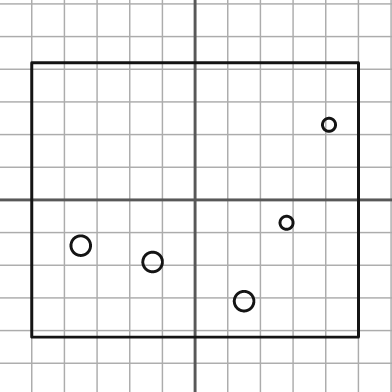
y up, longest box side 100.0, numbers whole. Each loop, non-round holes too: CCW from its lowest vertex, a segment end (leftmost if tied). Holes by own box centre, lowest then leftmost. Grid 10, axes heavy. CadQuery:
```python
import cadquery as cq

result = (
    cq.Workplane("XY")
    .moveTo(-50.0, -42.0)
    .lineTo(50.0, -42.0)
    .lineTo(50.0, 42.0)
    .lineTo(-50.0, 42.0)
    .close()
    .moveTo(15.0, -31.0)
    .circle(3.0)
    .moveTo(-13.0, -19.0)
    .circle(3.0)
    .moveTo(-35.0, -14.0)
    .circle(3.0)
    .moveTo(28.0, -7.0)
    .circle(2.0)
    .moveTo(41.0, 23.0)
    .circle(2.0)
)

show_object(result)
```